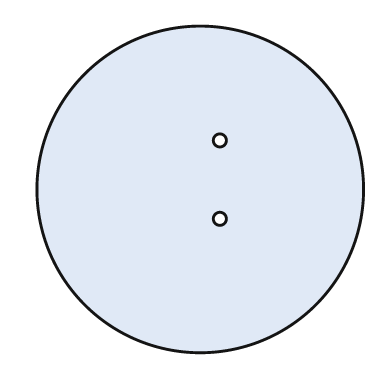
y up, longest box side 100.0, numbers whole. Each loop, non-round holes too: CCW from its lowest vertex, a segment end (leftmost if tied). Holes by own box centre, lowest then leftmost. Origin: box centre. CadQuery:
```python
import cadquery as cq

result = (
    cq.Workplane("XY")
    .moveTo(0.0, 0.0)
    .circle(50.0)
    .moveTo(6.0, -9.0)
    .circle(2.0)
    .moveTo(6.0, 15.0)
    .circle(2.0)
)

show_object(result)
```